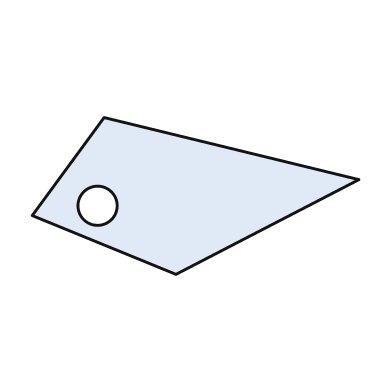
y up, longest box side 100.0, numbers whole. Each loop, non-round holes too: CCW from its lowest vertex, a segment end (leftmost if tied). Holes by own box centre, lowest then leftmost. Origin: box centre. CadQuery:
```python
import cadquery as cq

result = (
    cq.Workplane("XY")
    .moveTo(-6.0, -24.0)
    .lineTo(50.0, 5.0)
    .lineTo(-28.0, 24.0)
    .lineTo(-50.0, -6.0)
    .close()
    .moveTo(-30.0, -3.0)
    .circle(6.0)
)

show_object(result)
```